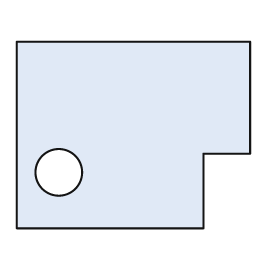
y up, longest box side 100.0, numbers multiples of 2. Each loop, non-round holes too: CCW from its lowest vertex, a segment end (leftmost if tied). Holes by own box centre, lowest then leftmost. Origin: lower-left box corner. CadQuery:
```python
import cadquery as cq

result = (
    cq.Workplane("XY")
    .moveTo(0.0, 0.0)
    .lineTo(80.0, 0.0)
    .lineTo(80.0, 32.0)
    .lineTo(100.0, 32.0)
    .lineTo(100.0, 80.0)
    .lineTo(0.0, 80.0)
    .close()
    .moveTo(18.0, 24.0)
    .circle(10.0)
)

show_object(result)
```